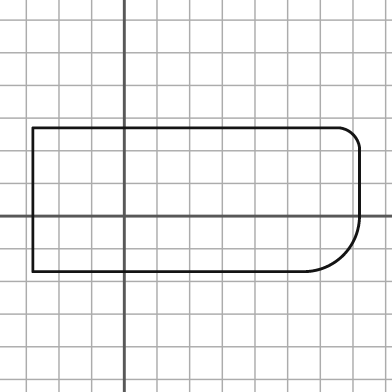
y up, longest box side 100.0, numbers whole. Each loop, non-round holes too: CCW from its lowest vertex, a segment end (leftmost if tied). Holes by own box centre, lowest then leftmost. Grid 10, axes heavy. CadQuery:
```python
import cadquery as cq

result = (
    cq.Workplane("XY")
    .moveTo(-28.0, -17.0)
    .lineTo(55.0, -17.0)
    .threePointArc((67.0, -12.0), (72.0, 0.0))
    .lineTo(72.0, 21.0)
    .threePointArc((70.0, 25.0), (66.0, 27.0))
    .lineTo(-28.0, 27.0)
    .close()
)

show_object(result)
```